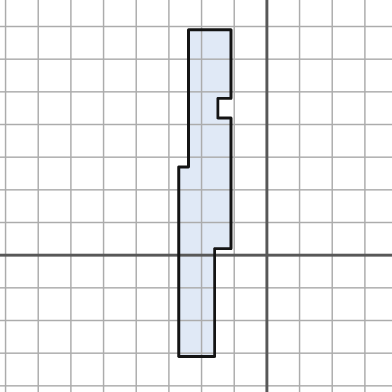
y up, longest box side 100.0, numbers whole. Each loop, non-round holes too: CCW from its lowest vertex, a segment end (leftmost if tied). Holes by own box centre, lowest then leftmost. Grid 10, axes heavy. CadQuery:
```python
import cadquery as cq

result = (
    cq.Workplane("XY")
    .moveTo(-27.0, -31.0)
    .lineTo(-16.0, -31.0)
    .lineTo(-16.0, 2.0)
    .lineTo(-11.0, 2.0)
    .lineTo(-11.0, 42.0)
    .lineTo(-15.0, 42.0)
    .lineTo(-15.0, 48.0)
    .lineTo(-11.0, 48.0)
    .lineTo(-11.0, 69.0)
    .lineTo(-24.0, 69.0)
    .lineTo(-24.0, 27.0)
    .lineTo(-27.0, 27.0)
    .close()
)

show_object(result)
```